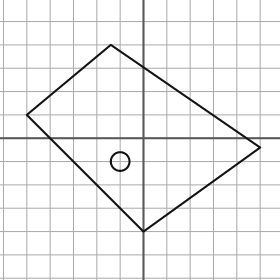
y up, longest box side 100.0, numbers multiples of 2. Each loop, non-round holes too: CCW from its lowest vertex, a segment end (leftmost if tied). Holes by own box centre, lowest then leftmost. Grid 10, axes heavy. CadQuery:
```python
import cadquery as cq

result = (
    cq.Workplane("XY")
    .moveTo(0.0, -40.0)
    .lineTo(50.0, -4.0)
    .lineTo(-14.0, 40.0)
    .lineTo(-50.0, 10.0)
    .close()
    .moveTo(-10.0, -10.0)
    .circle(4.0)
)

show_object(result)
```